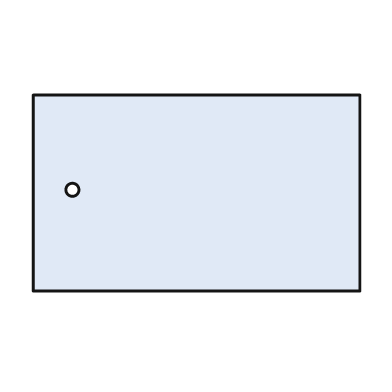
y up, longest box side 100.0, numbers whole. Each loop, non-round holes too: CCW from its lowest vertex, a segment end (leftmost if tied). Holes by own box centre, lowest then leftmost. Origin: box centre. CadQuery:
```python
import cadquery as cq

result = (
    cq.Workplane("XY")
    .moveTo(-50.0, -30.0)
    .lineTo(50.0, -30.0)
    .lineTo(50.0, 30.0)
    .lineTo(-50.0, 30.0)
    .close()
    .moveTo(-38.0, 1.0)
    .circle(2.0)
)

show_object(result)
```